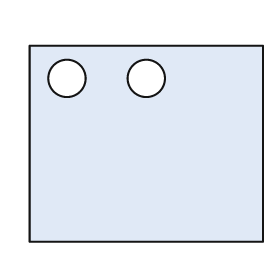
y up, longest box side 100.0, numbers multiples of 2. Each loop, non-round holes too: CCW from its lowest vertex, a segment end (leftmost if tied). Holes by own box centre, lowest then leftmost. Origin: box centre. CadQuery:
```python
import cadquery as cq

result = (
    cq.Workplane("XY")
    .moveTo(-50.0, -42.0)
    .lineTo(50.0, -42.0)
    .lineTo(50.0, 42.0)
    .lineTo(-50.0, 42.0)
    .close()
    .moveTo(-34.0, 28.0)
    .circle(8.0)
    .moveTo(0.0, 28.0)
    .circle(8.0)
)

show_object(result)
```